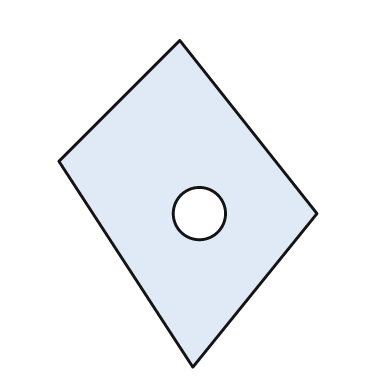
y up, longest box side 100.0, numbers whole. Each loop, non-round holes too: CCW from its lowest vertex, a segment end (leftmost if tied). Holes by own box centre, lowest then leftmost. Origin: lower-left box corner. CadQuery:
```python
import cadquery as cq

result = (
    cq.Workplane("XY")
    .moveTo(41.0, 0.0)
    .lineTo(79.0, 47.0)
    .lineTo(37.0, 100.0)
    .lineTo(0.0, 63.0)
    .close()
    .moveTo(43.0, 47.0)
    .circle(8.0)
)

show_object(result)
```